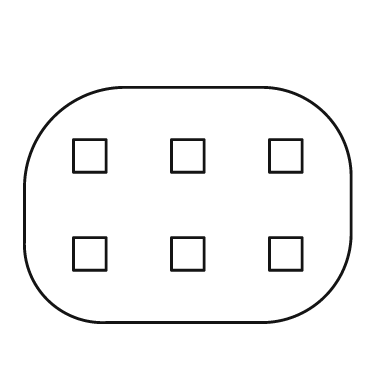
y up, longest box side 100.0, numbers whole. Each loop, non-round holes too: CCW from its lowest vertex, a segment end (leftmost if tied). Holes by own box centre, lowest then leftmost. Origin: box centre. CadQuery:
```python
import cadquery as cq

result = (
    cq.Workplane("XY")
    .moveTo(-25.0, -36.0)
    .lineTo(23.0, -36.0)
    .threePointArc((42.0, -28.0), (50.0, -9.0))
    .lineTo(50.0, 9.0)
    .threePointArc((42.0, 28.0), (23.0, 36.0))
    .lineTo(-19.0, 36.0)
    .threePointArc((-41.0, 27.0), (-50.0, 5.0))
    .lineTo(-50.0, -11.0)
    .threePointArc((-43.0, -29.0), (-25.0, -36.0))
    .close()
    .moveTo(-35.0, -20.0)
    .lineTo(-25.0, -20.0)
    .lineTo(-25.0, -10.0)
    .lineTo(-35.0, -10.0)
    .close()
    .moveTo(-5.0, -20.0)
    .lineTo(5.0, -20.0)
    .lineTo(5.0, -10.0)
    .lineTo(-5.0, -10.0)
    .close()
    .moveTo(25.0, -20.0)
    .lineTo(35.0, -20.0)
    .lineTo(35.0, -10.0)
    .lineTo(25.0, -10.0)
    .close()
    .moveTo(-35.0, 10.0)
    .lineTo(-25.0, 10.0)
    .lineTo(-25.0, 20.0)
    .lineTo(-35.0, 20.0)
    .close()
    .moveTo(-5.0, 10.0)
    .lineTo(5.0, 10.0)
    .lineTo(5.0, 20.0)
    .lineTo(-5.0, 20.0)
    .close()
    .moveTo(25.0, 10.0)
    .lineTo(35.0, 10.0)
    .lineTo(35.0, 20.0)
    .lineTo(25.0, 20.0)
    .close()
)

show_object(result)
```